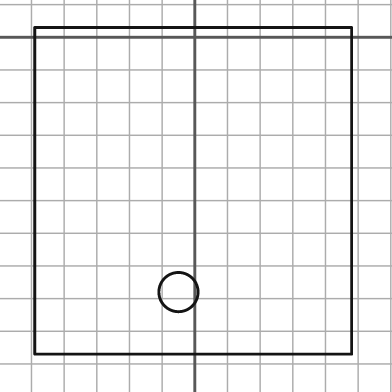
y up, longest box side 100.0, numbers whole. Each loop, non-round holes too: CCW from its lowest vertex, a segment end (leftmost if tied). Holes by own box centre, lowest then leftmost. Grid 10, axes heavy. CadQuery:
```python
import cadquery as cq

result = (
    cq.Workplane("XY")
    .moveTo(-49.0, -97.0)
    .lineTo(48.0, -97.0)
    .lineTo(48.0, 3.0)
    .lineTo(-49.0, 3.0)
    .close()
    .moveTo(-5.0, -78.0)
    .circle(6.0)
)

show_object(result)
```